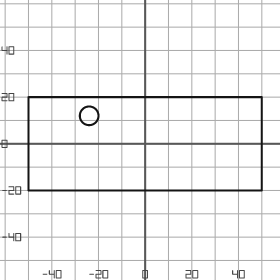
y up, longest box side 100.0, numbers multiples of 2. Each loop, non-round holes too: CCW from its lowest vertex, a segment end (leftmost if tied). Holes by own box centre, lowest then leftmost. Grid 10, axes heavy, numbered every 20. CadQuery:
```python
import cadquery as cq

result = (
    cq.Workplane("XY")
    .moveTo(-50.0, -20.0)
    .lineTo(50.0, -20.0)
    .lineTo(50.0, 20.0)
    .lineTo(-50.0, 20.0)
    .close()
    .moveTo(-24.0, 12.0)
    .circle(4.0)
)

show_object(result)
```